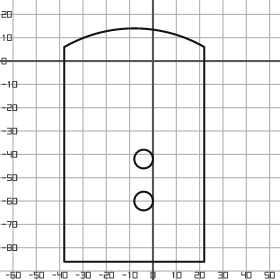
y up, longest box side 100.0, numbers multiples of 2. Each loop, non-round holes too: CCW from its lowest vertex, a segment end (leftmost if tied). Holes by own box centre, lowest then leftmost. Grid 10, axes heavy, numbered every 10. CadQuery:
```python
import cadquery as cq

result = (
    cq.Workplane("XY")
    .moveTo(-38.0, -86.0)
    .lineTo(22.0, -86.0)
    .lineTo(22.0, 6.0)
    .threePointArc((-8.0, 14.0), (-38.0, 6.0))
    .close()
    .moveTo(-4.0, -60.0)
    .circle(4.0)
    .moveTo(-4.0, -42.0)
    .circle(4.0)
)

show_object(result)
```